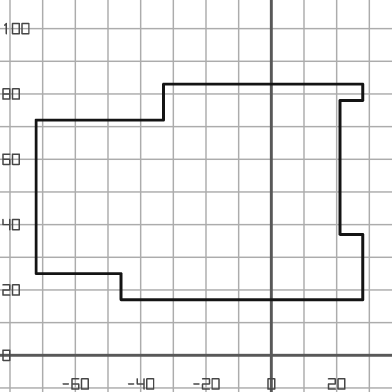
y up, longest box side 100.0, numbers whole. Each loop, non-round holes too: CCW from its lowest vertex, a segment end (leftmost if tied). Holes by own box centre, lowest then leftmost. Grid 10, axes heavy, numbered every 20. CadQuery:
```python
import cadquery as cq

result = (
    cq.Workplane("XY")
    .moveTo(-46.0, 17.0)
    .lineTo(28.0, 17.0)
    .lineTo(28.0, 37.0)
    .lineTo(21.0, 37.0)
    .lineTo(21.0, 78.0)
    .lineTo(28.0, 78.0)
    .lineTo(28.0, 83.0)
    .lineTo(-33.0, 83.0)
    .lineTo(-33.0, 72.0)
    .lineTo(-72.0, 72.0)
    .lineTo(-72.0, 25.0)
    .lineTo(-46.0, 25.0)
    .close()
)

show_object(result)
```